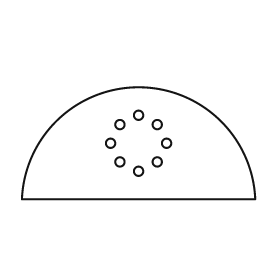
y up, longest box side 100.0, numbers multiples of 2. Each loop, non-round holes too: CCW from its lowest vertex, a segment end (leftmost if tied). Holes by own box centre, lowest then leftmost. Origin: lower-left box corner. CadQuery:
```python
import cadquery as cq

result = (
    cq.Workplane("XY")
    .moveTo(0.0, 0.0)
    .lineTo(100.0, 0.0)
    .threePointArc((50.0, 48.0), (0.0, 0.0))
    .close()
    .moveTo(50.0, 12.0)
    .circle(2.0)
    .moveTo(42.0, 16.0)
    .circle(2.0)
    .moveTo(58.0, 16.0)
    .circle(2.0)
    .moveTo(38.0, 24.0)
    .circle(2.0)
    .moveTo(62.0, 24.0)
    .circle(2.0)
    .moveTo(42.0, 32.0)
    .circle(2.0)
    .moveTo(58.0, 32.0)
    .circle(2.0)
    .moveTo(50.0, 36.0)
    .circle(2.0)
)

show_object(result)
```